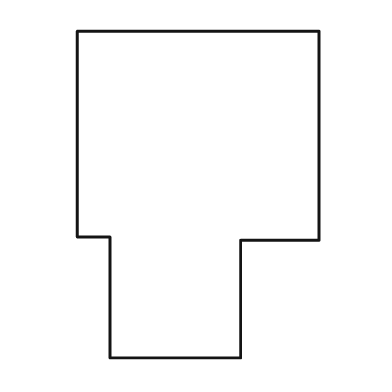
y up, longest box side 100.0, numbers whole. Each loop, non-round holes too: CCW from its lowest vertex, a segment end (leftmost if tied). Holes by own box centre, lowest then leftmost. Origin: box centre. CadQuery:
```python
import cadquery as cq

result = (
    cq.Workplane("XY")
    .moveTo(-27.0, -50.0)
    .lineTo(13.0, -50.0)
    .lineTo(13.0, -14.0)
    .lineTo(37.0, -14.0)
    .lineTo(37.0, 50.0)
    .lineTo(-37.0, 50.0)
    .lineTo(-37.0, -13.0)
    .lineTo(-27.0, -13.0)
    .close()
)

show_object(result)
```